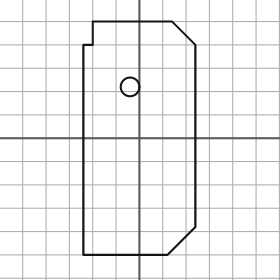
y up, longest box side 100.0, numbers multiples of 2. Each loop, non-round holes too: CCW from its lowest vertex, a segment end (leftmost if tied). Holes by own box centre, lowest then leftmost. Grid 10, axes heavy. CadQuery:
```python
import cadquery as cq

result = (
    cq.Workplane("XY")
    .moveTo(-24.0, -50.0)
    .lineTo(12.0, -50.0)
    .lineTo(24.0, -38.0)
    .lineTo(24.0, 40.0)
    .lineTo(14.0, 50.0)
    .lineTo(-20.0, 50.0)
    .lineTo(-20.0, 40.0)
    .lineTo(-24.0, 40.0)
    .close()
    .moveTo(-4.0, 22.0)
    .circle(4.0)
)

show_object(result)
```